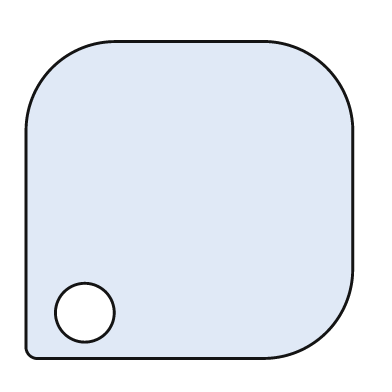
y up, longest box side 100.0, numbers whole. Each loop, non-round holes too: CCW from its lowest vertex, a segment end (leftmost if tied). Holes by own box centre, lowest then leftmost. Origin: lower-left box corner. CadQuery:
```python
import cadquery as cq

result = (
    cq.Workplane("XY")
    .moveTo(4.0, 0.0)
    .lineTo(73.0, 0.0)
    .threePointArc((92.0, 8.0), (100.0, 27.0))
    .lineTo(100.0, 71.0)
    .threePointArc((92.0, 89.0), (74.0, 97.0))
    .lineTo(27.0, 97.0)
    .threePointArc((8.0, 89.0), (0.0, 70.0))
    .lineTo(0.0, 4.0)
    .threePointArc((1.0, 1.0), (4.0, 0.0))
    .close()
    .moveTo(18.0, 14.0)
    .circle(9.0)
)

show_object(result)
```